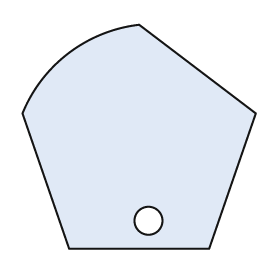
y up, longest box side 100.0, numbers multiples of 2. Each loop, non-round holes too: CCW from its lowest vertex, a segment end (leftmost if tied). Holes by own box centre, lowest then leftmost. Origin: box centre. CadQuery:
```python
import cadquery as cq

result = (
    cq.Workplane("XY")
    .moveTo(-30.0, -48.0)
    .lineTo(30.0, -48.0)
    .lineTo(50.0, 10.0)
    .lineTo(0.0, 48.0)
    .threePointArc((-30.0, 36.0), (-50.0, 10.0))
    .close()
    .moveTo(4.0, -36.0)
    .circle(6.0)
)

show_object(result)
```